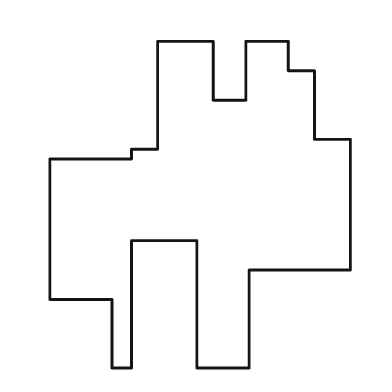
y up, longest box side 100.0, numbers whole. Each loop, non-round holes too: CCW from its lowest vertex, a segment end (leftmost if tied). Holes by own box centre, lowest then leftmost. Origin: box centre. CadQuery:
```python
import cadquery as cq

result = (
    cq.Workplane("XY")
    .moveTo(-27.0, -50.0)
    .lineTo(-21.0, -50.0)
    .lineTo(-21.0, -11.0)
    .lineTo(-1.0, -11.0)
    .lineTo(-1.0, -50.0)
    .lineTo(15.0, -50.0)
    .lineTo(15.0, -20.0)
    .lineTo(46.0, -20.0)
    .lineTo(46.0, 20.0)
    .lineTo(35.0, 20.0)
    .lineTo(35.0, 41.0)
    .lineTo(27.0, 41.0)
    .lineTo(27.0, 50.0)
    .lineTo(14.0, 50.0)
    .lineTo(14.0, 32.0)
    .lineTo(4.0, 32.0)
    .lineTo(4.0, 50.0)
    .lineTo(-13.0, 50.0)
    .lineTo(-13.0, 17.0)
    .lineTo(-21.0, 17.0)
    .lineTo(-21.0, 14.0)
    .lineTo(-46.0, 14.0)
    .lineTo(-46.0, -29.0)
    .lineTo(-27.0, -29.0)
    .close()
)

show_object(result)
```